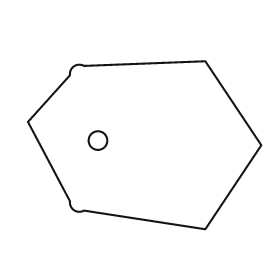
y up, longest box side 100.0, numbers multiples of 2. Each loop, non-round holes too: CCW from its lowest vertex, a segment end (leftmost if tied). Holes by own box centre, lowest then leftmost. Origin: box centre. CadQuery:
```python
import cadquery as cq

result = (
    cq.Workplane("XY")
    .moveTo(26.0, -36.0)
    .lineTo(50.0, 0.0)
    .lineTo(26.0, 36.0)
    .lineTo(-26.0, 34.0)
    .threePointArc((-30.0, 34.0), (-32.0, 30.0))
    .lineTo(-50.0, 10.0)
    .lineTo(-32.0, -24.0)
    .threePointArc((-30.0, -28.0), (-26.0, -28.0))
    .close()
    .moveTo(-20.0, 2.0)
    .circle(4.0)
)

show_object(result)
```